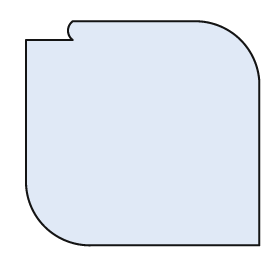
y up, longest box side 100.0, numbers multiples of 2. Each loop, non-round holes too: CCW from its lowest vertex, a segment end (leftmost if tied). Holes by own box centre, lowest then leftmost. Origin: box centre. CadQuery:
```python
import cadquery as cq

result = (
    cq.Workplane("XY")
    .moveTo(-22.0, -48.0)
    .lineTo(50.0, -48.0)
    .lineTo(50.0, 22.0)
    .threePointArc((42.0, 40.0), (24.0, 48.0))
    .lineTo(-30.0, 48.0)
    .threePointArc((-32.0, 44.0), (-30.0, 40.0))
    .lineTo(-50.0, 40.0)
    .lineTo(-50.0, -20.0)
    .threePointArc((-42.0, -40.0), (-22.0, -48.0))
    .close()
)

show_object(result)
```